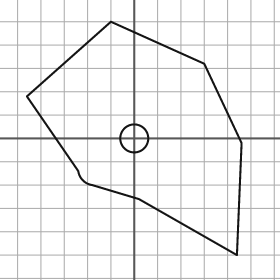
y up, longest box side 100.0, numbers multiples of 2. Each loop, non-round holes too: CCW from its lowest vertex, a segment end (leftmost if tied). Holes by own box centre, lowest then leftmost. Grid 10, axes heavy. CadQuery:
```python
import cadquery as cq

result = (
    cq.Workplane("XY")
    .moveTo(44.0, -50.0)
    .lineTo(46.0, -2.0)
    .lineTo(30.0, 32.0)
    .lineTo(-10.0, 50.0)
    .lineTo(-46.0, 18.0)
    .lineTo(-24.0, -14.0)
    .threePointArc((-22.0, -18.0), (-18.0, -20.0))
    .lineTo(2.0, -26.0)
    .close()
    .moveTo(0.0, 0.0)
    .circle(6.0)
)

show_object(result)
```